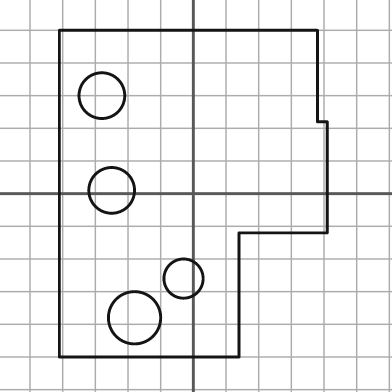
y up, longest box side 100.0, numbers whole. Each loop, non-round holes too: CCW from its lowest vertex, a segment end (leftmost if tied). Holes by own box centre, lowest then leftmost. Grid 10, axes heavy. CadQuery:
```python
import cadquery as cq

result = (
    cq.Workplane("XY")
    .moveTo(-41.0, -50.0)
    .lineTo(14.0, -50.0)
    .lineTo(14.0, -12.0)
    .lineTo(41.0, -12.0)
    .lineTo(41.0, 22.0)
    .lineTo(38.0, 22.0)
    .lineTo(38.0, 50.0)
    .lineTo(-41.0, 50.0)
    .close()
    .moveTo(-18.0, -38.0)
    .circle(8.0)
    .moveTo(-3.0, -26.0)
    .circle(6.0)
    .moveTo(-25.0, 1.0)
    .circle(7.0)
    .moveTo(-28.0, 30.0)
    .circle(7.0)
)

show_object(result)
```